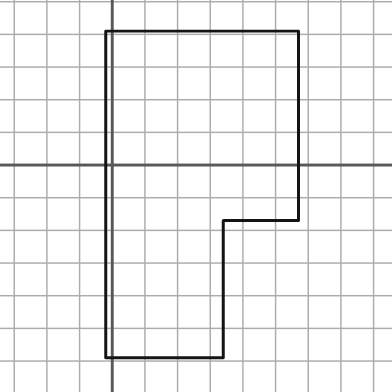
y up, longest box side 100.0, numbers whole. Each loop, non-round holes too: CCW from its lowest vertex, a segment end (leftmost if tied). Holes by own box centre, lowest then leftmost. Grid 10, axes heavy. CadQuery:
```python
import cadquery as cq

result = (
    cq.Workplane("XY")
    .moveTo(-2.0, -59.0)
    .lineTo(34.0, -59.0)
    .lineTo(34.0, -17.0)
    .lineTo(57.0, -17.0)
    .lineTo(57.0, 41.0)
    .lineTo(-2.0, 41.0)
    .close()
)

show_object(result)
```